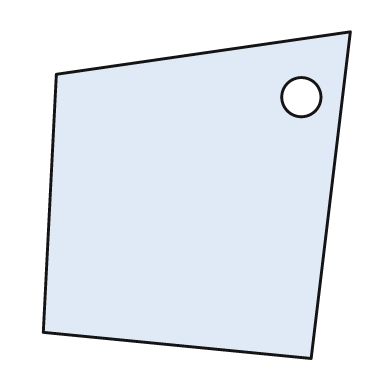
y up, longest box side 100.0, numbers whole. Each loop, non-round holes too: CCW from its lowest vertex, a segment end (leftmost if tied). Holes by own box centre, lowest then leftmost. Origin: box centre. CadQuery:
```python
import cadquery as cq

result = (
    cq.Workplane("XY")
    .moveTo(35.0, -50.0)
    .lineTo(47.0, 50.0)
    .lineTo(-43.0, 37.0)
    .lineTo(-47.0, -42.0)
    .close()
    .moveTo(32.0, 30.0)
    .circle(6.0)
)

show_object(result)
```